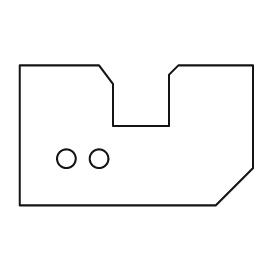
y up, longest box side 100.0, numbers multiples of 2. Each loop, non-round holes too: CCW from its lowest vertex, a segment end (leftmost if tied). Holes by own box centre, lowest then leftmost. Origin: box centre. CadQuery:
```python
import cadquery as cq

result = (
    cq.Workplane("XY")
    .moveTo(-50.0, -30.0)
    .lineTo(34.0, -30.0)
    .lineTo(50.0, -14.0)
    .lineTo(50.0, 30.0)
    .lineTo(18.0, 30.0)
    .lineTo(14.0, 26.0)
    .lineTo(14.0, 4.0)
    .lineTo(-10.0, 4.0)
    .lineTo(-10.0, 22.0)
    .lineTo(-16.0, 30.0)
    .lineTo(-50.0, 30.0)
    .close()
    .moveTo(-30.0, -10.0)
    .circle(4.0)
    .moveTo(-16.0, -10.0)
    .circle(4.0)
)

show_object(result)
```